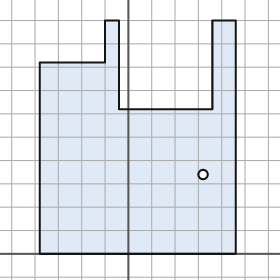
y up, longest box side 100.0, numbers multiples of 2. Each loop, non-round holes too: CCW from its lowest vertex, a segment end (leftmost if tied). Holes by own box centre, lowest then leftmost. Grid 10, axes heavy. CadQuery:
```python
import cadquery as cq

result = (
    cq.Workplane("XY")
    .moveTo(-38.0, 0.0)
    .lineTo(46.0, 0.0)
    .lineTo(46.0, 100.0)
    .lineTo(36.0, 100.0)
    .lineTo(36.0, 62.0)
    .lineTo(-4.0, 62.0)
    .lineTo(-4.0, 100.0)
    .lineTo(-10.0, 100.0)
    .lineTo(-10.0, 82.0)
    .lineTo(-38.0, 82.0)
    .close()
    .moveTo(32.0, 34.0)
    .circle(2.0)
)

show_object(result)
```